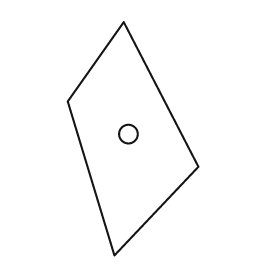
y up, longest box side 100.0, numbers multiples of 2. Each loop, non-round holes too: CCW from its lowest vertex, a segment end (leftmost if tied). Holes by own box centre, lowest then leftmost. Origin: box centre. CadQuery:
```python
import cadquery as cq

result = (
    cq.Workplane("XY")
    .moveTo(-8.0, -50.0)
    .lineTo(28.0, -12.0)
    .lineTo(-4.0, 50.0)
    .lineTo(-28.0, 16.0)
    .close()
    .moveTo(-2.0, 2.0)
    .circle(4.0)
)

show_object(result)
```